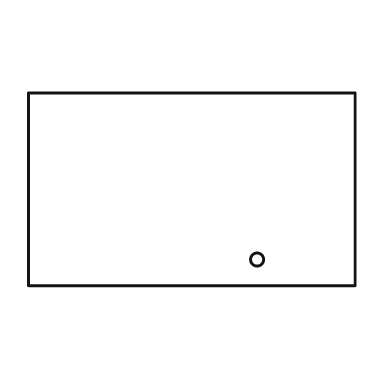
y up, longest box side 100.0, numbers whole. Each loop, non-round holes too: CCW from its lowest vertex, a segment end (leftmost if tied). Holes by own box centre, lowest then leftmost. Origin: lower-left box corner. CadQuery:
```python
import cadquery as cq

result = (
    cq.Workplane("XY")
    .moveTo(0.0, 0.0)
    .lineTo(100.0, 0.0)
    .lineTo(100.0, 59.0)
    .lineTo(0.0, 59.0)
    .close()
    .moveTo(70.0, 8.0)
    .circle(2.0)
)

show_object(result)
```